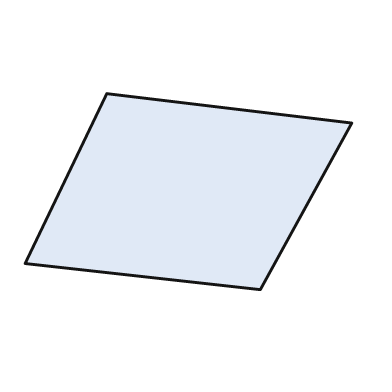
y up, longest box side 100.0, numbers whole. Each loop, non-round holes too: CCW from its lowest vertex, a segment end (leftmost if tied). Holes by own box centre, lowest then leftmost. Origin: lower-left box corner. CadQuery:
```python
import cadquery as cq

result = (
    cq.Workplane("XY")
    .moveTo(72.0, 0.0)
    .lineTo(100.0, 51.0)
    .lineTo(25.0, 60.0)
    .lineTo(0.0, 8.0)
    .close()
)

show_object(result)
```